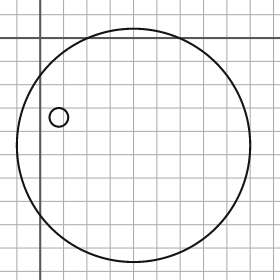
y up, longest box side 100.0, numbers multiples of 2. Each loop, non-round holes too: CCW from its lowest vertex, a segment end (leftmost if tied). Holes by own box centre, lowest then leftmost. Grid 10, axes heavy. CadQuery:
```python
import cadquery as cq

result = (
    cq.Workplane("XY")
    .moveTo(40.0, -46.0)
    .circle(50.0)
    .moveTo(8.0, -34.0)
    .circle(4.0)
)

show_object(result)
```